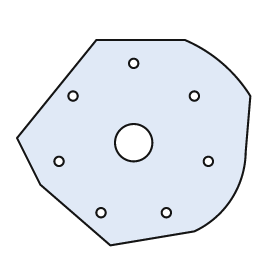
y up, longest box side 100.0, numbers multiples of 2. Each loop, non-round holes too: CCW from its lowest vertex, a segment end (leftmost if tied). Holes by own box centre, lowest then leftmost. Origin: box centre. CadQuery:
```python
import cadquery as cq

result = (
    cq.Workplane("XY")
    .moveTo(-10.0, -44.0)
    .lineTo(26.0, -38.0)
    .threePointArc((42.0, -24.0), (48.0, -4.0))
    .lineTo(50.0, 20.0)
    .threePointArc((38.0, 34.0), (22.0, 44.0))
    .lineTo(-16.0, 44.0)
    .lineTo(-50.0, 2.0)
    .lineTo(-40.0, -18.0)
    .close()
    .moveTo(-14.0, -30.0)
    .circle(2.0)
    .moveTo(14.0, -30.0)
    .circle(2.0)
    .moveTo(-32.0, -8.0)
    .circle(2.0)
    .moveTo(32.0, -8.0)
    .circle(2.0)
    .moveTo(0.0, 0.0)
    .circle(8.0)
    .moveTo(-26.0, 20.0)
    .circle(2.0)
    .moveTo(26.0, 20.0)
    .circle(2.0)
    .moveTo(0.0, 34.0)
    .circle(2.0)
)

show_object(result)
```